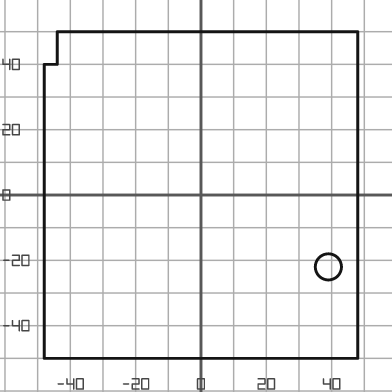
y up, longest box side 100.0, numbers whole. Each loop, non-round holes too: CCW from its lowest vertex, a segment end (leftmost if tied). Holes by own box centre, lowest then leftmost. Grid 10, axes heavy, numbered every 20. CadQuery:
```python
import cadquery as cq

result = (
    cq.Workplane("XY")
    .moveTo(-48.0, -50.0)
    .lineTo(48.0, -50.0)
    .lineTo(48.0, 50.0)
    .lineTo(-44.0, 50.0)
    .lineTo(-44.0, 40.0)
    .lineTo(-48.0, 40.0)
    .close()
    .moveTo(39.0, -22.0)
    .circle(4.0)
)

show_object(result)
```